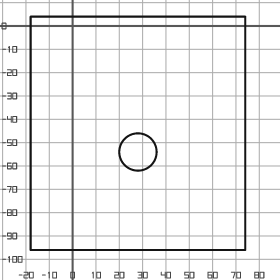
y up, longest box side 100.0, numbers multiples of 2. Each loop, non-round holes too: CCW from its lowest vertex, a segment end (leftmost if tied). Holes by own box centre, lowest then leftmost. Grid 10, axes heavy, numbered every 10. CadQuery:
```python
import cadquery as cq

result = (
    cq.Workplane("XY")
    .moveTo(-18.0, -96.0)
    .lineTo(74.0, -96.0)
    .lineTo(74.0, 4.0)
    .lineTo(-18.0, 4.0)
    .close()
    .moveTo(28.0, -54.0)
    .circle(8.0)
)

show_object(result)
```